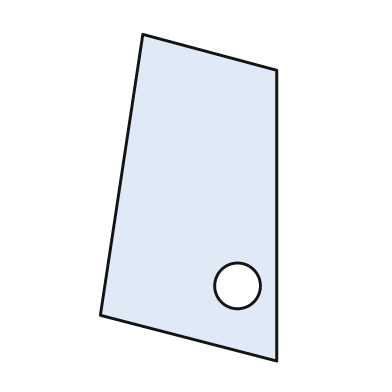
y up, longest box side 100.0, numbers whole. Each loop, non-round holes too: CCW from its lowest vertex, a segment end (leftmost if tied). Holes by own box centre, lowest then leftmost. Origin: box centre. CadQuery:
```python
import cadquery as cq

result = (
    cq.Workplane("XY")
    .moveTo(27.0, -50.0)
    .lineTo(27.0, 39.0)
    .lineTo(-14.0, 50.0)
    .lineTo(-27.0, -36.0)
    .close()
    .moveTo(15.0, -27.0)
    .circle(7.0)
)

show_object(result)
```